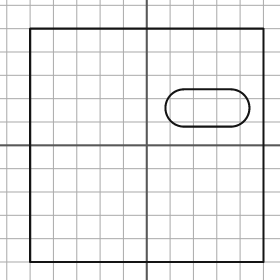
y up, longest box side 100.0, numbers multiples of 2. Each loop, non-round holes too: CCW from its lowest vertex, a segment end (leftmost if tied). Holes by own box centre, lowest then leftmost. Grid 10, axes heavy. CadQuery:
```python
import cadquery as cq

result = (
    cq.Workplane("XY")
    .moveTo(-50.0, -50.0)
    .lineTo(50.0, -50.0)
    .lineTo(50.0, 50.0)
    .lineTo(-50.0, 50.0)
    .close()
    .moveTo(16.0, 8.0)
    .lineTo(36.0, 8.0)
    .threePointArc((44.0, 16.0), (36.0, 24.0))
    .lineTo(16.0, 24.0)
    .threePointArc((8.0, 16.0), (16.0, 8.0))
    .close()
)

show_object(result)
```